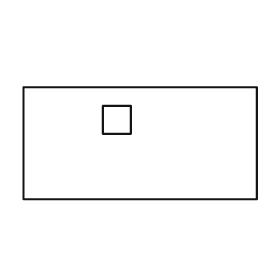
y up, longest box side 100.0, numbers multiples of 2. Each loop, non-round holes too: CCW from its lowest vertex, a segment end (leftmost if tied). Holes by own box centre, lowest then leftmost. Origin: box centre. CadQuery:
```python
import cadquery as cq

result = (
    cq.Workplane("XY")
    .moveTo(-50.0, -24.0)
    .lineTo(50.0, -24.0)
    .lineTo(50.0, 24.0)
    .lineTo(-50.0, 24.0)
    .close()
    .moveTo(-16.0, 4.0)
    .lineTo(-4.0, 4.0)
    .lineTo(-4.0, 16.0)
    .lineTo(-16.0, 16.0)
    .close()
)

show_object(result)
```